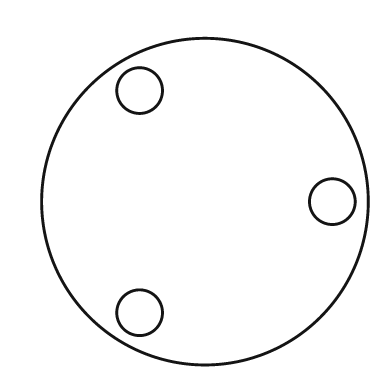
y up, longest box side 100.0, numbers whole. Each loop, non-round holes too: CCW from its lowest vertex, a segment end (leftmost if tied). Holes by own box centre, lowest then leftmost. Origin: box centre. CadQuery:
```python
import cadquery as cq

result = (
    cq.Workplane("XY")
    .moveTo(0.0, 0.0)
    .circle(50.0)
    .moveTo(-20.0, -34.0)
    .circle(7.0)
    .moveTo(39.0, 0.0)
    .circle(7.0)
    .moveTo(-20.0, 34.0)
    .circle(7.0)
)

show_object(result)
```